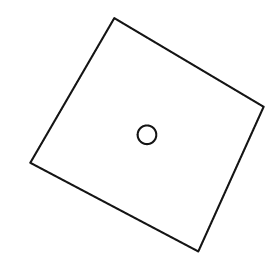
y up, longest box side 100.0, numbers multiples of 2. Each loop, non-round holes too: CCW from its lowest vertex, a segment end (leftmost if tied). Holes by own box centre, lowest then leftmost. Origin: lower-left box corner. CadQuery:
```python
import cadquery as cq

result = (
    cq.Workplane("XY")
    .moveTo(72.0, 0.0)
    .lineTo(100.0, 62.0)
    .lineTo(36.0, 100.0)
    .lineTo(0.0, 38.0)
    .close()
    .moveTo(50.0, 50.0)
    .circle(4.0)
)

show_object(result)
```